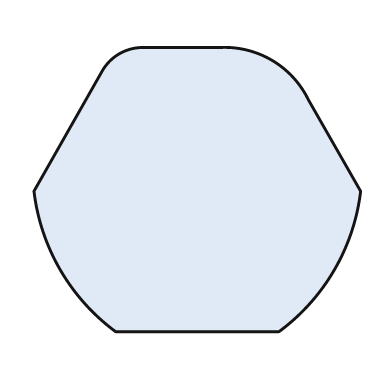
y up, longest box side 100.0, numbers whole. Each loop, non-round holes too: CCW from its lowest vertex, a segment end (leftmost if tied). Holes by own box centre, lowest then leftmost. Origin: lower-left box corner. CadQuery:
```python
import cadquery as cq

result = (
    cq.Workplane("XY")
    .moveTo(25.0, 0.0)
    .lineTo(75.0, 0.0)
    .threePointArc((92.0, 19.0), (100.0, 43.0))
    .lineTo(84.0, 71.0)
    .threePointArc((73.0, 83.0), (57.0, 87.0))
    .lineTo(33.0, 87.0)
    .threePointArc((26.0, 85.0), (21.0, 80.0))
    .lineTo(0.0, 43.0)
    .threePointArc((8.0, 19.0), (25.0, 0.0))
    .close()
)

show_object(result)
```